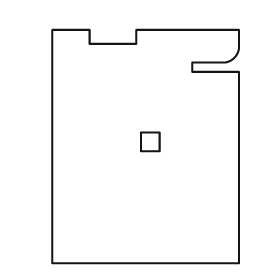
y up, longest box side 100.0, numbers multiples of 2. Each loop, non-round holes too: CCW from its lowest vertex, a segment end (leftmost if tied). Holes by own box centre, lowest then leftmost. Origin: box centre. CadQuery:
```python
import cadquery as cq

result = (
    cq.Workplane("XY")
    .moveTo(-40.0, -50.0)
    .lineTo(40.0, -50.0)
    .lineTo(40.0, 32.0)
    .lineTo(20.0, 32.0)
    .lineTo(20.0, 36.0)
    .lineTo(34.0, 36.0)
    .threePointArc((38.0, 38.0), (40.0, 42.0))
    .lineTo(40.0, 50.0)
    .lineTo(-4.0, 50.0)
    .lineTo(-4.0, 44.0)
    .lineTo(-24.0, 44.0)
    .lineTo(-24.0, 50.0)
    .lineTo(-40.0, 50.0)
    .close()
    .moveTo(-2.0, -2.0)
    .lineTo(6.0, -2.0)
    .lineTo(6.0, 6.0)
    .lineTo(-2.0, 6.0)
    .close()
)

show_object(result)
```